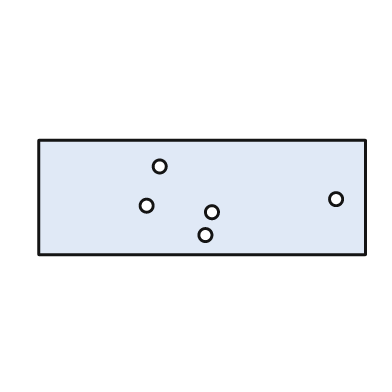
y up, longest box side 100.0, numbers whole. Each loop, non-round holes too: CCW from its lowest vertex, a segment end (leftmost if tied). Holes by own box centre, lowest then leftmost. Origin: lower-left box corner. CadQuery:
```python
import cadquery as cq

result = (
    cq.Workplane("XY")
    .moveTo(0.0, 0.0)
    .lineTo(100.0, 0.0)
    .lineTo(100.0, 35.0)
    .lineTo(0.0, 35.0)
    .close()
    .moveTo(51.0, 6.0)
    .circle(2.0)
    .moveTo(53.0, 13.0)
    .circle(2.0)
    .moveTo(33.0, 15.0)
    .circle(2.0)
    .moveTo(91.0, 17.0)
    .circle(2.0)
    .moveTo(37.0, 27.0)
    .circle(2.0)
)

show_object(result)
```